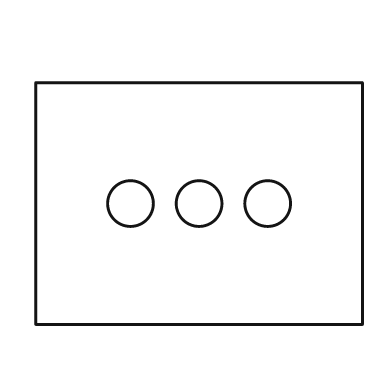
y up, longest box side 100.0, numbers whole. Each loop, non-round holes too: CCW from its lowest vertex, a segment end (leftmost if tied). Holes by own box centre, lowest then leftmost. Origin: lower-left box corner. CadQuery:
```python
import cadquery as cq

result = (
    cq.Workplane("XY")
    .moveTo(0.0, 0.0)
    .lineTo(100.0, 0.0)
    .lineTo(100.0, 74.0)
    .lineTo(0.0, 74.0)
    .close()
    .moveTo(29.0, 37.0)
    .circle(7.0)
    .moveTo(50.0, 37.0)
    .circle(7.0)
    .moveTo(71.0, 37.0)
    .circle(7.0)
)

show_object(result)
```